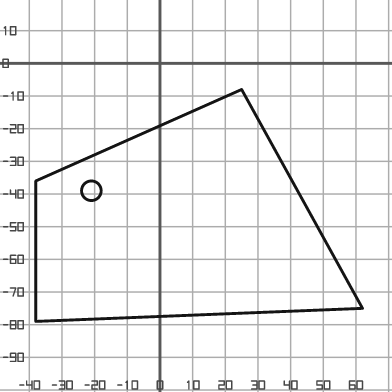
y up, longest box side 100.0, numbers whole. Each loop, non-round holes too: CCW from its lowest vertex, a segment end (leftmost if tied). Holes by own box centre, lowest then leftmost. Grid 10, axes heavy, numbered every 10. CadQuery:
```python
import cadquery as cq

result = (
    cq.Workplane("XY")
    .moveTo(-38.0, -79.0)
    .lineTo(62.0, -75.0)
    .lineTo(25.0, -8.0)
    .lineTo(-38.0, -36.0)
    .close()
    .moveTo(-21.0, -39.0)
    .circle(3.0)
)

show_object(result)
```